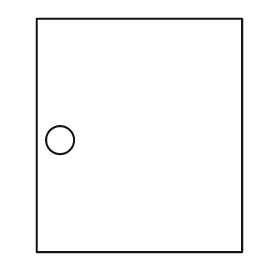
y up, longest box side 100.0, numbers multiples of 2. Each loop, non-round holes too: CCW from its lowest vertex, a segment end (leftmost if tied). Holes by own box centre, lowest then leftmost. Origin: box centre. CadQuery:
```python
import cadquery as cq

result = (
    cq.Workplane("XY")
    .moveTo(-44.0, -50.0)
    .lineTo(44.0, -50.0)
    .lineTo(44.0, 50.0)
    .lineTo(-44.0, 50.0)
    .close()
    .moveTo(-34.0, -2.0)
    .circle(6.0)
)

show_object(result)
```